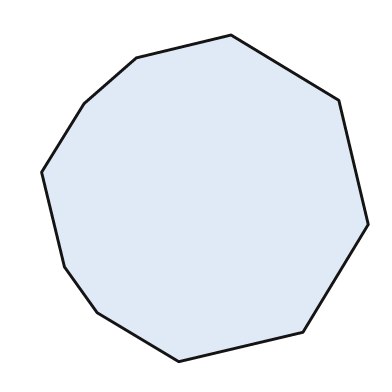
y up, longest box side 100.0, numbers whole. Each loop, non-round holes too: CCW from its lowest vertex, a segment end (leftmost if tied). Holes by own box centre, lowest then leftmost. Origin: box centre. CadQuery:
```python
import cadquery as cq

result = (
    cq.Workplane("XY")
    .moveTo(-8.0, -50.0)
    .lineTo(30.0, -41.0)
    .lineTo(50.0, -8.0)
    .lineTo(41.0, 30.0)
    .lineTo(8.0, 50.0)
    .lineTo(-21.0, 43.0)
    .lineTo(-37.0, 29.0)
    .lineTo(-50.0, 8.0)
    .lineTo(-43.0, -21.0)
    .lineTo(-33.0, -35.0)
    .close()
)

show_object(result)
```